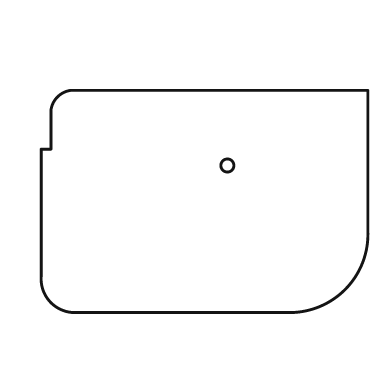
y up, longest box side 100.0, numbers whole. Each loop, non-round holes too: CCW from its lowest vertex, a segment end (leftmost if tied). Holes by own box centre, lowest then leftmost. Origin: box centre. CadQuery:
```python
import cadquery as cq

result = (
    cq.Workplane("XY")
    .moveTo(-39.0, -34.0)
    .lineTo(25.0, -34.0)
    .threePointArc((43.0, -27.0), (50.0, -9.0))
    .lineTo(50.0, 34.0)
    .lineTo(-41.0, 34.0)
    .threePointArc((-45.0, 32.0), (-47.0, 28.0))
    .lineTo(-47.0, 16.0)
    .lineTo(-50.0, 16.0)
    .lineTo(-50.0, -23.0)
    .threePointArc((-47.0, -31.0), (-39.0, -34.0))
    .close()
    .moveTo(7.0, 11.0)
    .circle(2.0)
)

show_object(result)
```